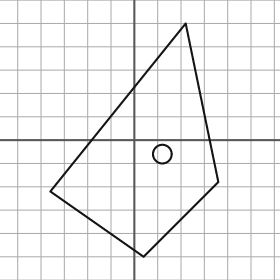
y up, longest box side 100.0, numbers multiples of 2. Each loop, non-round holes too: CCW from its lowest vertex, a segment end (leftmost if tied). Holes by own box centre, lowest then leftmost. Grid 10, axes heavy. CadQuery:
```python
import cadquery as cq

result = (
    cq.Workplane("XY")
    .moveTo(4.0, -50.0)
    .lineTo(36.0, -18.0)
    .lineTo(22.0, 50.0)
    .lineTo(-36.0, -22.0)
    .close()
    .moveTo(12.0, -6.0)
    .circle(4.0)
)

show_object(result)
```